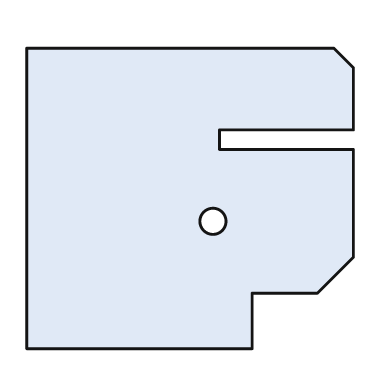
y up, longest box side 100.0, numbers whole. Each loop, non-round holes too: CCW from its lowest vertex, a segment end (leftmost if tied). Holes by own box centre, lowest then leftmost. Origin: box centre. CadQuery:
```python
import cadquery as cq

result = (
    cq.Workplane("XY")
    .moveTo(-50.0, -46.0)
    .lineTo(19.0, -46.0)
    .lineTo(19.0, -29.0)
    .lineTo(39.0, -29.0)
    .lineTo(50.0, -18.0)
    .lineTo(50.0, 15.0)
    .lineTo(9.0, 15.0)
    .lineTo(9.0, 21.0)
    .lineTo(50.0, 21.0)
    .lineTo(50.0, 40.0)
    .lineTo(44.0, 46.0)
    .lineTo(-50.0, 46.0)
    .close()
    .moveTo(7.0, -7.0)
    .circle(4.0)
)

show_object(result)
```